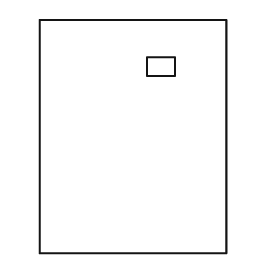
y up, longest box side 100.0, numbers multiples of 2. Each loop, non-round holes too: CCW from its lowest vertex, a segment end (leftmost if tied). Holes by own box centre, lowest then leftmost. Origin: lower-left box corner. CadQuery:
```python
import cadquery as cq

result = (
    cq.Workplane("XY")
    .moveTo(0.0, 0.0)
    .lineTo(80.0, 0.0)
    .lineTo(80.0, 100.0)
    .lineTo(0.0, 100.0)
    .close()
    .moveTo(46.0, 76.0)
    .lineTo(58.0, 76.0)
    .lineTo(58.0, 84.0)
    .lineTo(46.0, 84.0)
    .close()
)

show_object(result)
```